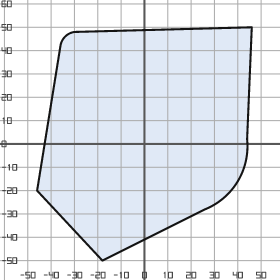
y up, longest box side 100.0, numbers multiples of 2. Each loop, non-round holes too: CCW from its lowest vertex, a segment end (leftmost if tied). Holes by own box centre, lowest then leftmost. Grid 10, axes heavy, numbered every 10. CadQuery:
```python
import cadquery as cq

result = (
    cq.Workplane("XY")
    .moveTo(-18.0, -50.0)
    .lineTo(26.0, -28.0)
    .threePointArc((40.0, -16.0), (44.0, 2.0))
    .lineTo(46.0, 50.0)
    .lineTo(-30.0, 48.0)
    .threePointArc((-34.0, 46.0), (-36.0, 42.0))
    .lineTo(-46.0, -20.0)
    .close()
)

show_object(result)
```